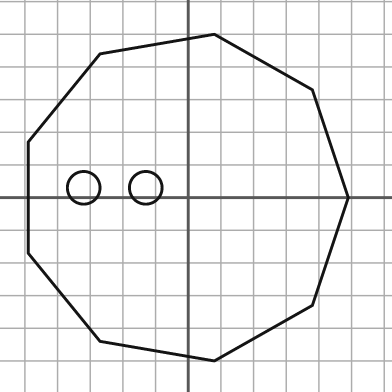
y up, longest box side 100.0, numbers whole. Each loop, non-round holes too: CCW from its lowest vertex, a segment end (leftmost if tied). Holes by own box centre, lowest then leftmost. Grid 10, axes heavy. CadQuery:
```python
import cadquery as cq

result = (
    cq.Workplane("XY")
    .moveTo(8.0, -50.0)
    .lineTo(38.0, -33.0)
    .lineTo(49.0, 0.0)
    .lineTo(38.0, 33.0)
    .lineTo(8.0, 50.0)
    .lineTo(-27.0, 44.0)
    .lineTo(-49.0, 17.0)
    .lineTo(-49.0, -17.0)
    .lineTo(-27.0, -44.0)
    .close()
    .moveTo(-32.0, 3.0)
    .circle(5.0)
    .moveTo(-13.0, 3.0)
    .circle(5.0)
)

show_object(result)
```